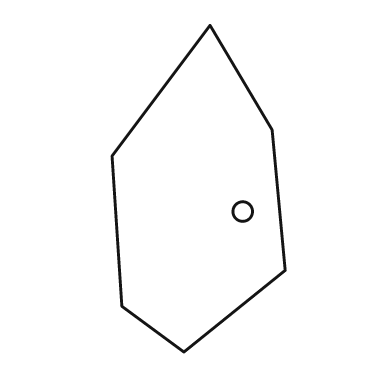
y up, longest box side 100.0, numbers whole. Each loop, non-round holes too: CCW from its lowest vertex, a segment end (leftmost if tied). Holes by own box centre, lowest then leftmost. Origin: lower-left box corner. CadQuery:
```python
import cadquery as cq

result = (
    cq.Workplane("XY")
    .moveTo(22.0, 0.0)
    .lineTo(53.0, 25.0)
    .lineTo(49.0, 68.0)
    .lineTo(30.0, 100.0)
    .lineTo(0.0, 60.0)
    .lineTo(3.0, 14.0)
    .close()
    .moveTo(40.0, 43.0)
    .circle(3.0)
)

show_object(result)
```